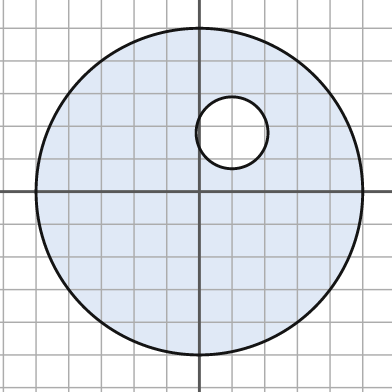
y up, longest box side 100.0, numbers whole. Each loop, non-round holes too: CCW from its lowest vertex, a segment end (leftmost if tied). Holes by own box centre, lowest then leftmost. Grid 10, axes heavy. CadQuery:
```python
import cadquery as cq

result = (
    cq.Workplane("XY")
    .moveTo(0.0, 0.0)
    .circle(50.0)
    .moveTo(10.0, 18.0)
    .circle(11.0)
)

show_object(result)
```